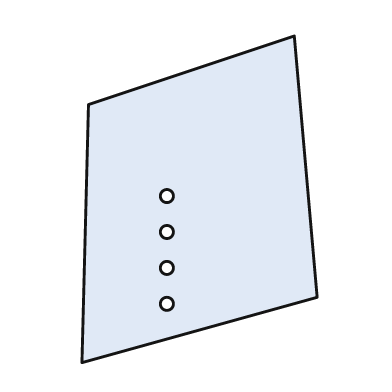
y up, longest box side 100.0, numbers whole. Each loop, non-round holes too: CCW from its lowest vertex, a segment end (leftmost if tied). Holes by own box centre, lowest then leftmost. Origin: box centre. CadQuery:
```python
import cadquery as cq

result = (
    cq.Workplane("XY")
    .moveTo(-36.0, -50.0)
    .lineTo(36.0, -30.0)
    .lineTo(29.0, 50.0)
    .lineTo(-34.0, 29.0)
    .close()
    .moveTo(-10.0, -32.0)
    .circle(2.0)
    .moveTo(-10.0, -21.0)
    .circle(2.0)
    .moveTo(-10.0, -10.0)
    .circle(2.0)
    .moveTo(-10.0, 1.0)
    .circle(2.0)
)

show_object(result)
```